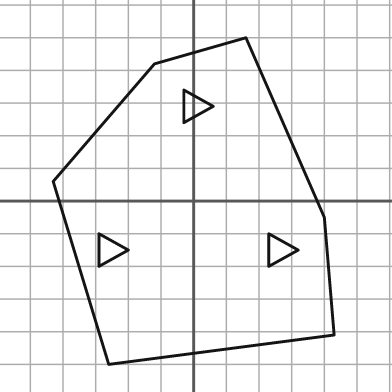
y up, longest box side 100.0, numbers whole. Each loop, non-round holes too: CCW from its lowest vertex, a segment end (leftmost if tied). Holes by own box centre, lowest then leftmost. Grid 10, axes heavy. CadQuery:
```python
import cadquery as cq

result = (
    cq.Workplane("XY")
    .moveTo(-26.0, -50.0)
    .lineTo(43.0, -41.0)
    .lineTo(40.0, -5.0)
    .lineTo(16.0, 50.0)
    .lineTo(-12.0, 42.0)
    .lineTo(-43.0, 6.0)
    .close()
    .moveTo(-29.0, -20.0)
    .lineTo(-20.0, -15.0)
    .lineTo(-29.0, -10.0)
    .close()
    .moveTo(23.0, -20.0)
    .lineTo(32.0, -15.0)
    .lineTo(23.0, -10.0)
    .close()
    .moveTo(-3.0, 24.0)
    .lineTo(6.0, 29.0)
    .lineTo(-3.0, 34.0)
    .close()
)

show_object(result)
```